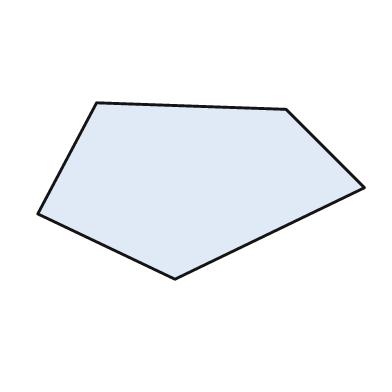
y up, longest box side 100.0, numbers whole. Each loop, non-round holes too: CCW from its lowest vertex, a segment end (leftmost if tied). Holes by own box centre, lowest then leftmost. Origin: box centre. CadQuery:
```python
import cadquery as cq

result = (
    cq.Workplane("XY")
    .moveTo(-8.0, -27.0)
    .lineTo(50.0, 1.0)
    .lineTo(26.0, 25.0)
    .lineTo(-32.0, 27.0)
    .lineTo(-50.0, -7.0)
    .close()
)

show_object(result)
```